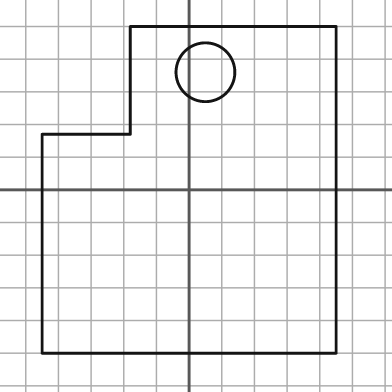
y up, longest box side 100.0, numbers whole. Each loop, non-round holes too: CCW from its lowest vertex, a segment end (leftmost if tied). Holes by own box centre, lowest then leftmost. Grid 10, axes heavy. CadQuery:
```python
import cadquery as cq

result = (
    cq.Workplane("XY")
    .moveTo(-45.0, -50.0)
    .lineTo(45.0, -50.0)
    .lineTo(45.0, 50.0)
    .lineTo(-18.0, 50.0)
    .lineTo(-18.0, 17.0)
    .lineTo(-45.0, 17.0)
    .close()
    .moveTo(5.0, 36.0)
    .circle(9.0)
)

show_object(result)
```